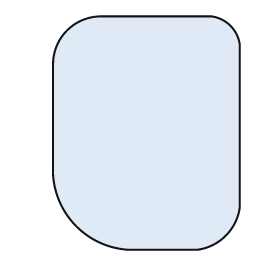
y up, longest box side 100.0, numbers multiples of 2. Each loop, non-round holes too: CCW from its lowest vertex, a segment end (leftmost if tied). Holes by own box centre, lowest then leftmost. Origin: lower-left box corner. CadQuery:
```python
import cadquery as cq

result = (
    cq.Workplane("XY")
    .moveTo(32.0, 0.0)
    .lineTo(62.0, 0.0)
    .threePointArc((74.0, 6.0), (80.0, 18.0))
    .lineTo(80.0, 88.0)
    .threePointArc((76.0, 96.0), (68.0, 100.0))
    .lineTo(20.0, 100.0)
    .threePointArc((6.0, 94.0), (0.0, 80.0))
    .lineTo(0.0, 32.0)
    .threePointArc((10.0, 10.0), (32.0, 0.0))
    .close()
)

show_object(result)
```